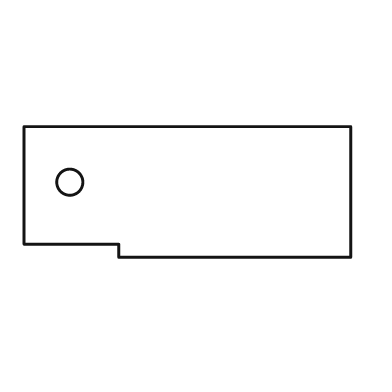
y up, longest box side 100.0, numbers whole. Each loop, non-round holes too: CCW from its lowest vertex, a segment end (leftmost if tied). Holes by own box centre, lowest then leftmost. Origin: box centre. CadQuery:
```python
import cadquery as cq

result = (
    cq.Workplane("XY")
    .moveTo(-21.0, -20.0)
    .lineTo(50.0, -20.0)
    .lineTo(50.0, 20.0)
    .lineTo(-50.0, 20.0)
    .lineTo(-50.0, -16.0)
    .lineTo(-21.0, -16.0)
    .close()
    .moveTo(-36.0, 3.0)
    .circle(4.0)
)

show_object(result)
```